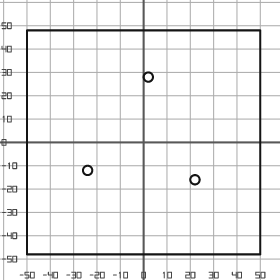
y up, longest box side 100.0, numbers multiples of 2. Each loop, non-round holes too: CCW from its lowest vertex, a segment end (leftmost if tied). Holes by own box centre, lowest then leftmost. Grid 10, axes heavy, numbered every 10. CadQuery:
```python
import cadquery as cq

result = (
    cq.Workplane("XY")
    .moveTo(-50.0, -48.0)
    .lineTo(50.0, -48.0)
    .lineTo(50.0, 48.0)
    .lineTo(-50.0, 48.0)
    .close()
    .moveTo(22.0, -16.0)
    .circle(2.0)
    .moveTo(-24.0, -12.0)
    .circle(2.0)
    .moveTo(2.0, 28.0)
    .circle(2.0)
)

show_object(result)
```